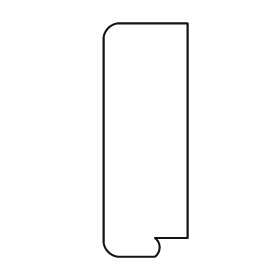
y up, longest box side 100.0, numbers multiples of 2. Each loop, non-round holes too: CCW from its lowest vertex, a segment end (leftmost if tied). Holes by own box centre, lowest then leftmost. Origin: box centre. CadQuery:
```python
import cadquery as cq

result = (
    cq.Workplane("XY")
    .moveTo(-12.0, -50.0)
    .lineTo(4.0, -50.0)
    .threePointArc((6.0, -46.0), (4.0, -42.0))
    .lineTo(18.0, -42.0)
    .lineTo(18.0, 50.0)
    .lineTo(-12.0, 50.0)
    .threePointArc((-16.0, 48.0), (-18.0, 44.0))
    .lineTo(-18.0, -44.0)
    .threePointArc((-16.0, -48.0), (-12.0, -50.0))
    .close()
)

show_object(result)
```